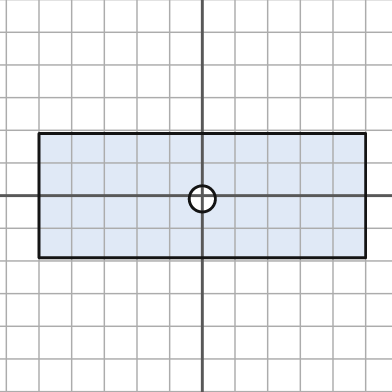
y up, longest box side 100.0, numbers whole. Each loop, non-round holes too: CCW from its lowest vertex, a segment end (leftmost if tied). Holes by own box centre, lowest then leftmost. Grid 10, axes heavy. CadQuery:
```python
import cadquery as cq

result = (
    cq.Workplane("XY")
    .moveTo(-50.0, -19.0)
    .lineTo(50.0, -19.0)
    .lineTo(50.0, 19.0)
    .lineTo(-50.0, 19.0)
    .close()
    .moveTo(0.0, -1.0)
    .circle(4.0)
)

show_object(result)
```